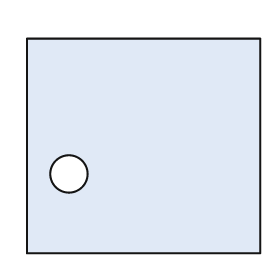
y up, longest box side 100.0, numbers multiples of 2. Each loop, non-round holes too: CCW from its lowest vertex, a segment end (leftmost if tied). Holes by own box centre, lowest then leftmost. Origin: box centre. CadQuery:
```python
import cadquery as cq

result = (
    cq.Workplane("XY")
    .moveTo(-50.0, -46.0)
    .lineTo(50.0, -46.0)
    .lineTo(50.0, 46.0)
    .lineTo(-50.0, 46.0)
    .close()
    .moveTo(-32.0, -12.0)
    .circle(8.0)
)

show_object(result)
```